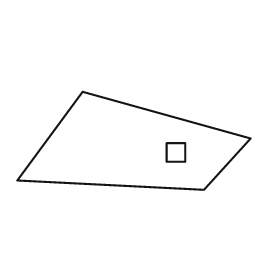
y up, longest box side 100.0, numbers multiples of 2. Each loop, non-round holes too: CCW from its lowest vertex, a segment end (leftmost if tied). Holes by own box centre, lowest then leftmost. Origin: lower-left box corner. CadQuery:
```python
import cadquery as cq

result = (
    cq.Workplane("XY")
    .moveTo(80.0, 0.0)
    .lineTo(100.0, 22.0)
    .lineTo(28.0, 42.0)
    .lineTo(0.0, 4.0)
    .close()
    .moveTo(64.0, 12.0)
    .lineTo(72.0, 12.0)
    .lineTo(72.0, 20.0)
    .lineTo(64.0, 20.0)
    .close()
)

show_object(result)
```